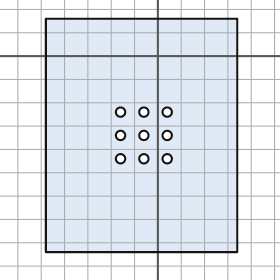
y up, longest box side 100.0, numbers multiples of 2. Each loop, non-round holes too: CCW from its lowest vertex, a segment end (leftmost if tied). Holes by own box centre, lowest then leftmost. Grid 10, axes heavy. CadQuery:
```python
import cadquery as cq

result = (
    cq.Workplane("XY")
    .moveTo(-48.0, -84.0)
    .lineTo(34.0, -84.0)
    .lineTo(34.0, 16.0)
    .lineTo(-48.0, 16.0)
    .close()
    .moveTo(-16.0, -44.0)
    .circle(2.0)
    .moveTo(-6.0, -44.0)
    .circle(2.0)
    .moveTo(4.0, -44.0)
    .circle(2.0)
    .moveTo(-16.0, -34.0)
    .circle(2.0)
    .moveTo(-6.0, -34.0)
    .circle(2.0)
    .moveTo(4.0, -34.0)
    .circle(2.0)
    .moveTo(-16.0, -24.0)
    .circle(2.0)
    .moveTo(-6.0, -24.0)
    .circle(2.0)
    .moveTo(4.0, -24.0)
    .circle(2.0)
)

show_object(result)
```